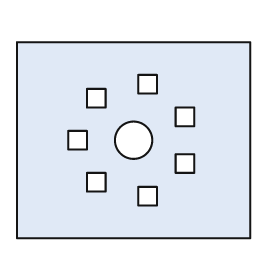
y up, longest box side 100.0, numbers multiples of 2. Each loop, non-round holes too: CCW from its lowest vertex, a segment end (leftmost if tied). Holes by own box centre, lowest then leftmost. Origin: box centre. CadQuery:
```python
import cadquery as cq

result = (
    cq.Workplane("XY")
    .moveTo(-50.0, -42.0)
    .lineTo(50.0, -42.0)
    .lineTo(50.0, 42.0)
    .lineTo(-50.0, 42.0)
    .close()
    .moveTo(2.0, -28.0)
    .lineTo(10.0, -28.0)
    .lineTo(10.0, -20.0)
    .lineTo(2.0, -20.0)
    .close()
    .moveTo(-20.0, -22.0)
    .lineTo(-12.0, -22.0)
    .lineTo(-12.0, -14.0)
    .lineTo(-20.0, -14.0)
    .close()
    .moveTo(18.0, -14.0)
    .lineTo(26.0, -14.0)
    .lineTo(26.0, -6.0)
    .lineTo(18.0, -6.0)
    .close()
    .moveTo(-28.0, -4.0)
    .lineTo(-20.0, -4.0)
    .lineTo(-20.0, 4.0)
    .lineTo(-28.0, 4.0)
    .close()
    .moveTo(0.0, 0.0)
    .circle(8.0)
    .moveTo(18.0, 6.0)
    .lineTo(26.0, 6.0)
    .lineTo(26.0, 14.0)
    .lineTo(18.0, 14.0)
    .close()
    .moveTo(-20.0, 14.0)
    .lineTo(-12.0, 14.0)
    .lineTo(-12.0, 22.0)
    .lineTo(-20.0, 22.0)
    .close()
    .moveTo(2.0, 20.0)
    .lineTo(10.0, 20.0)
    .lineTo(10.0, 28.0)
    .lineTo(2.0, 28.0)
    .close()
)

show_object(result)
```